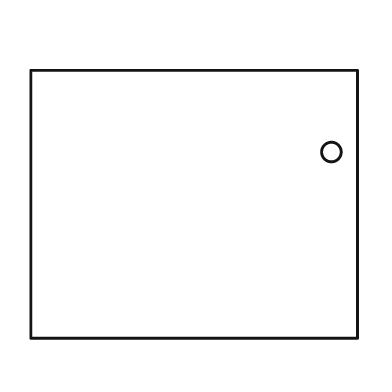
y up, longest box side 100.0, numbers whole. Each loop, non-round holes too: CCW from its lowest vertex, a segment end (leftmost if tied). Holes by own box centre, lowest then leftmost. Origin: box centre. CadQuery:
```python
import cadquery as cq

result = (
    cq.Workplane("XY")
    .moveTo(-50.0, -41.0)
    .lineTo(50.0, -41.0)
    .lineTo(50.0, 41.0)
    .lineTo(-50.0, 41.0)
    .close()
    .moveTo(42.0, 16.0)
    .circle(3.0)
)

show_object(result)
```